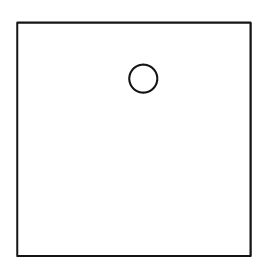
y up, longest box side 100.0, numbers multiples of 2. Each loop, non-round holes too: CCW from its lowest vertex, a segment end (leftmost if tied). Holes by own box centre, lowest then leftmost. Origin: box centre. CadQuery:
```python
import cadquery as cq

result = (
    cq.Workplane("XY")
    .moveTo(-50.0, -50.0)
    .lineTo(50.0, -50.0)
    .lineTo(50.0, 50.0)
    .lineTo(-50.0, 50.0)
    .close()
    .moveTo(4.0, 26.0)
    .circle(6.0)
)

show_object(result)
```